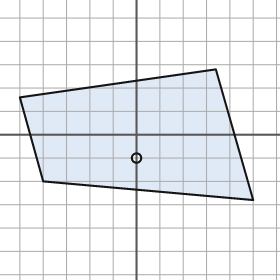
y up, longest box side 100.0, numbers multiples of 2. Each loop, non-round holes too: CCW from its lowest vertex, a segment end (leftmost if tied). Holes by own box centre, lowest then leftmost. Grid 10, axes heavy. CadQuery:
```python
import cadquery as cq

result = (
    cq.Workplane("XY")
    .moveTo(50.0, -28.0)
    .lineTo(34.0, 28.0)
    .lineTo(-50.0, 16.0)
    .lineTo(-40.0, -20.0)
    .close()
    .moveTo(0.0, -10.0)
    .circle(2.0)
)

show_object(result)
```